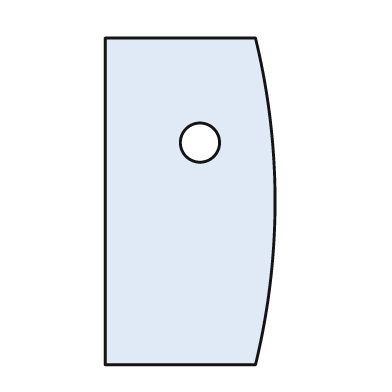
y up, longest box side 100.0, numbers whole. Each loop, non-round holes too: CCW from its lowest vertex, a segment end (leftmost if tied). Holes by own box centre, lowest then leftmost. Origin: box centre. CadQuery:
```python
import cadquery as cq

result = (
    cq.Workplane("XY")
    .moveTo(-26.0, -50.0)
    .lineTo(20.0, -50.0)
    .threePointArc((26.0, 0.0), (20.0, 50.0))
    .lineTo(-26.0, 50.0)
    .close()
    .moveTo(3.0, 18.0)
    .circle(6.0)
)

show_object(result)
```